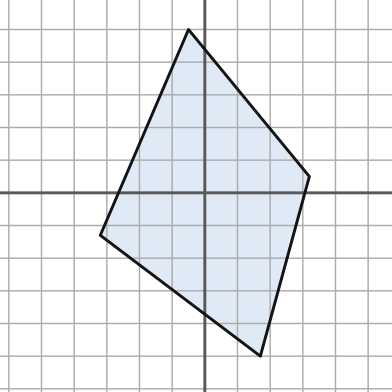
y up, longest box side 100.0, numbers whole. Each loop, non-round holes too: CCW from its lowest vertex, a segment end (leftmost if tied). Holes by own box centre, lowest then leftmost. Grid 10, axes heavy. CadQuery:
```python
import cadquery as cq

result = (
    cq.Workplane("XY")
    .moveTo(17.0, -50.0)
    .lineTo(32.0, 5.0)
    .lineTo(-5.0, 50.0)
    .lineTo(-32.0, -13.0)
    .close()
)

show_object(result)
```